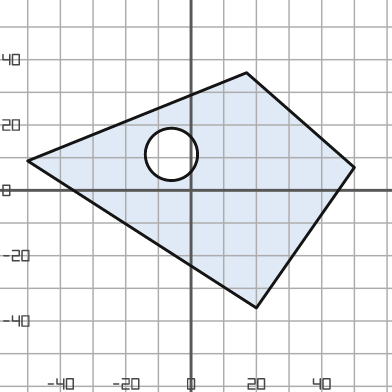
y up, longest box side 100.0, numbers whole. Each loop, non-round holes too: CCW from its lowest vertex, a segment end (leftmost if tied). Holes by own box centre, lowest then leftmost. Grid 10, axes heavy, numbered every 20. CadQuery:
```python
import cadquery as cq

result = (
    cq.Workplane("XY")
    .moveTo(20.0, -36.0)
    .lineTo(50.0, 7.0)
    .lineTo(17.0, 36.0)
    .lineTo(-50.0, 9.0)
    .close()
    .moveTo(-6.0, 11.0)
    .circle(8.0)
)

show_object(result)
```